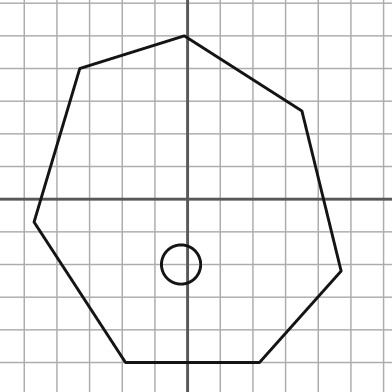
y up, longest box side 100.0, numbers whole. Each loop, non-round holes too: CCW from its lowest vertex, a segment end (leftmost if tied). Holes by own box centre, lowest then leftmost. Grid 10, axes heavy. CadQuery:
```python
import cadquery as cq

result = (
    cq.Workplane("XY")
    .moveTo(-19.0, -50.0)
    .lineTo(22.0, -50.0)
    .lineTo(47.0, -22.0)
    .lineTo(35.0, 27.0)
    .lineTo(-1.0, 50.0)
    .lineTo(-33.0, 40.0)
    .lineTo(-47.0, -7.0)
    .close()
    .moveTo(-2.0, -20.0)
    .circle(6.0)
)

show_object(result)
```